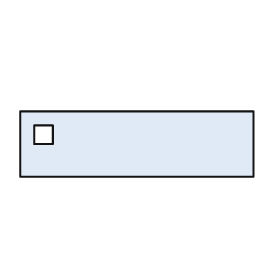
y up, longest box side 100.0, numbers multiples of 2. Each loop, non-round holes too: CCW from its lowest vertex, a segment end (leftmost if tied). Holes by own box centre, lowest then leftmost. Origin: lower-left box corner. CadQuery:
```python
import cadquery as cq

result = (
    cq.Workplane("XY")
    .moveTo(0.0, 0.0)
    .lineTo(100.0, 0.0)
    .lineTo(100.0, 28.0)
    .lineTo(0.0, 28.0)
    .close()
    .moveTo(6.0, 14.0)
    .lineTo(14.0, 14.0)
    .lineTo(14.0, 22.0)
    .lineTo(6.0, 22.0)
    .close()
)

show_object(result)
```